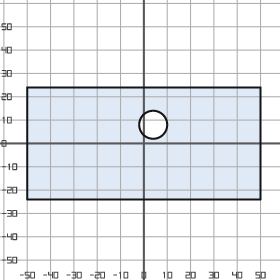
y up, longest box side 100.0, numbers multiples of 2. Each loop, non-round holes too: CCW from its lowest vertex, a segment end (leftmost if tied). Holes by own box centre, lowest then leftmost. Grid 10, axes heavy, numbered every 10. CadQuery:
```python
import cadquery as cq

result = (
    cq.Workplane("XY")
    .moveTo(-50.0, -24.0)
    .lineTo(50.0, -24.0)
    .lineTo(50.0, 24.0)
    .lineTo(-50.0, 24.0)
    .close()
    .moveTo(4.0, 8.0)
    .circle(6.0)
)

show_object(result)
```